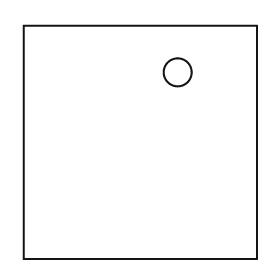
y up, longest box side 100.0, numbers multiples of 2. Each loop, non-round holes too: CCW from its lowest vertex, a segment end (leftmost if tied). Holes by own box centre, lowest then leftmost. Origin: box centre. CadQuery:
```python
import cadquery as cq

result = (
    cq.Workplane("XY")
    .moveTo(-50.0, -50.0)
    .lineTo(50.0, -50.0)
    .lineTo(50.0, 50.0)
    .lineTo(-50.0, 50.0)
    .close()
    .moveTo(16.0, 30.0)
    .circle(6.0)
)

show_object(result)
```